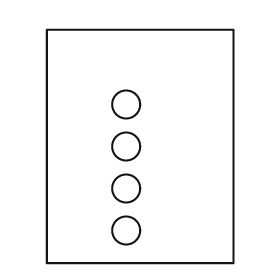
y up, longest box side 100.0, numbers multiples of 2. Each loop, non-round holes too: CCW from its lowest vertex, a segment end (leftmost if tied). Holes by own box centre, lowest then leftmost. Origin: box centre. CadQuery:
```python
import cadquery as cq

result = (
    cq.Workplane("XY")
    .moveTo(-40.0, -50.0)
    .lineTo(40.0, -50.0)
    .lineTo(40.0, 50.0)
    .lineTo(-40.0, 50.0)
    .close()
    .moveTo(-6.0, -36.0)
    .circle(6.0)
    .moveTo(-6.0, -18.0)
    .circle(6.0)
    .moveTo(-6.0, 0.0)
    .circle(6.0)
    .moveTo(-6.0, 18.0)
    .circle(6.0)
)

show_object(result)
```